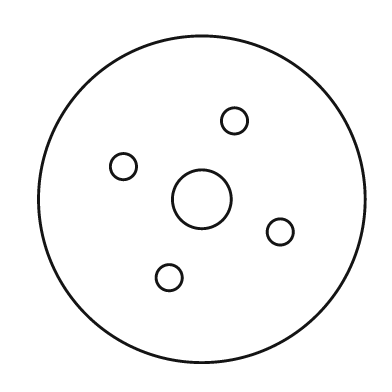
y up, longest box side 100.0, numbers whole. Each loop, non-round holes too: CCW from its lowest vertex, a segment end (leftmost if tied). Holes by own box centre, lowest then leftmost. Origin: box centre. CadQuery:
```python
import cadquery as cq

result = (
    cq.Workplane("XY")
    .moveTo(0.0, 0.0)
    .circle(50.0)
    .moveTo(-10.0, -24.0)
    .circle(4.0)
    .moveTo(24.0, -10.0)
    .circle(4.0)
    .moveTo(0.0, 0.0)
    .circle(9.0)
    .moveTo(-24.0, 10.0)
    .circle(4.0)
    .moveTo(10.0, 24.0)
    .circle(4.0)
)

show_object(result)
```